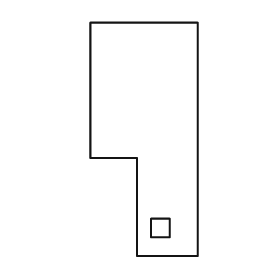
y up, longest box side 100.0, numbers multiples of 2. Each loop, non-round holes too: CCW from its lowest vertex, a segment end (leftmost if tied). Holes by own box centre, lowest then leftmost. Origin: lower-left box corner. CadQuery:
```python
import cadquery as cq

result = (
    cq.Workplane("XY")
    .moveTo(20.0, 0.0)
    .lineTo(46.0, 0.0)
    .lineTo(46.0, 100.0)
    .lineTo(0.0, 100.0)
    .lineTo(0.0, 42.0)
    .lineTo(20.0, 42.0)
    .close()
    .moveTo(26.0, 8.0)
    .lineTo(34.0, 8.0)
    .lineTo(34.0, 16.0)
    .lineTo(26.0, 16.0)
    .close()
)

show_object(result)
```